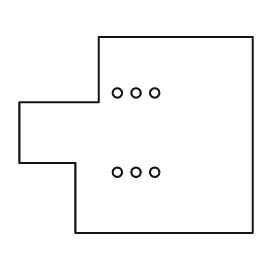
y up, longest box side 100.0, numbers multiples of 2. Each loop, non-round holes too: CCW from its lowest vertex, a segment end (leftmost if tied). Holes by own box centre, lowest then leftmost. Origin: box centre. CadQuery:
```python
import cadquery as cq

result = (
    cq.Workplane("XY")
    .moveTo(-26.0, -42.0)
    .lineTo(50.0, -42.0)
    .lineTo(50.0, 42.0)
    .lineTo(-16.0, 42.0)
    .lineTo(-16.0, 14.0)
    .lineTo(-50.0, 14.0)
    .lineTo(-50.0, -12.0)
    .lineTo(-26.0, -12.0)
    .close()
    .moveTo(-8.0, -16.0)
    .circle(2.0)
    .moveTo(0.0, -16.0)
    .circle(2.0)
    .moveTo(8.0, -16.0)
    .circle(2.0)
    .moveTo(-8.0, 18.0)
    .circle(2.0)
    .moveTo(0.0, 18.0)
    .circle(2.0)
    .moveTo(8.0, 18.0)
    .circle(2.0)
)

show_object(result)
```